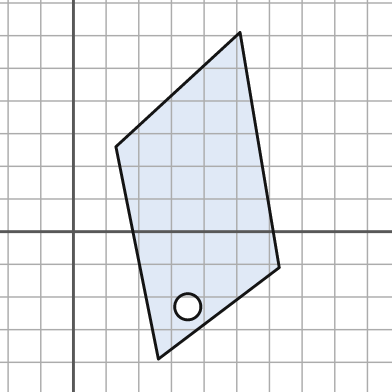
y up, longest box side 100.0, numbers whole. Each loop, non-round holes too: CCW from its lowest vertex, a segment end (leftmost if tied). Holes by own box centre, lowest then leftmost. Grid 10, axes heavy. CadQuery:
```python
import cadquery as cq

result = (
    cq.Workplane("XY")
    .moveTo(26.0, -39.0)
    .lineTo(63.0, -11.0)
    .lineTo(51.0, 61.0)
    .lineTo(13.0, 26.0)
    .close()
    .moveTo(35.0, -23.0)
    .circle(4.0)
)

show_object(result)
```